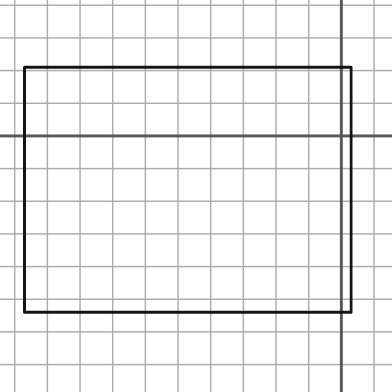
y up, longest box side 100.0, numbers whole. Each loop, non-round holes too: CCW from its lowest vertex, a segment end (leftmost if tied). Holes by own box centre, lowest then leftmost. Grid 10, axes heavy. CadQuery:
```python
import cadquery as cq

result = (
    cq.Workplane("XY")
    .moveTo(-97.0, -54.0)
    .lineTo(3.0, -54.0)
    .lineTo(3.0, 21.0)
    .lineTo(-97.0, 21.0)
    .close()
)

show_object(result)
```